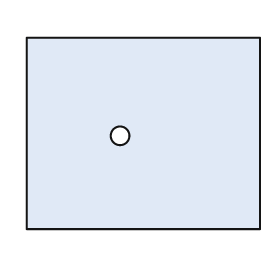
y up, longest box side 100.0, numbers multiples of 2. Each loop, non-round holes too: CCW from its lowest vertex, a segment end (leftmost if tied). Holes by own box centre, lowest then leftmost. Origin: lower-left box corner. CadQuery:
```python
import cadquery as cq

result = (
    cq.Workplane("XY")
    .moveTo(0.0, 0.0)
    .lineTo(100.0, 0.0)
    .lineTo(100.0, 82.0)
    .lineTo(0.0, 82.0)
    .close()
    .moveTo(40.0, 40.0)
    .circle(4.0)
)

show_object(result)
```